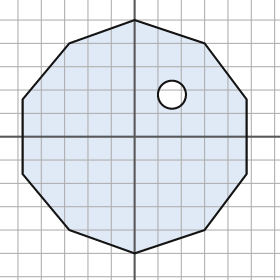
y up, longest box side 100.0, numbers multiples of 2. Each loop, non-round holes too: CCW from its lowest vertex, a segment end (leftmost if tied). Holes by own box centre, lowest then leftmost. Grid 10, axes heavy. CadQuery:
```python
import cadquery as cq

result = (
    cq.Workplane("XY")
    .moveTo(0.0, -50.0)
    .lineTo(30.0, -40.0)
    .lineTo(48.0, -16.0)
    .lineTo(48.0, 16.0)
    .lineTo(30.0, 40.0)
    .lineTo(0.0, 50.0)
    .lineTo(-28.0, 40.0)
    .lineTo(-48.0, 16.0)
    .lineTo(-48.0, -16.0)
    .lineTo(-28.0, -40.0)
    .close()
    .moveTo(16.0, 18.0)
    .circle(6.0)
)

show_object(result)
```